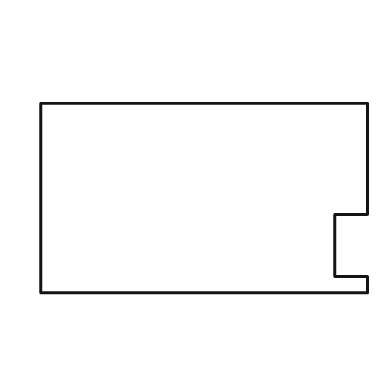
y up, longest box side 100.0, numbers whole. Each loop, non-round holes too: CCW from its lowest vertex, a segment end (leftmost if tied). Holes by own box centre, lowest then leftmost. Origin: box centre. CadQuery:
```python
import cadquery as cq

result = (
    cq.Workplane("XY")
    .moveTo(-50.0, -29.0)
    .lineTo(50.0, -29.0)
    .lineTo(50.0, -24.0)
    .lineTo(40.0, -24.0)
    .lineTo(40.0, -5.0)
    .lineTo(50.0, -5.0)
    .lineTo(50.0, 29.0)
    .lineTo(-50.0, 29.0)
    .close()
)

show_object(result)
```